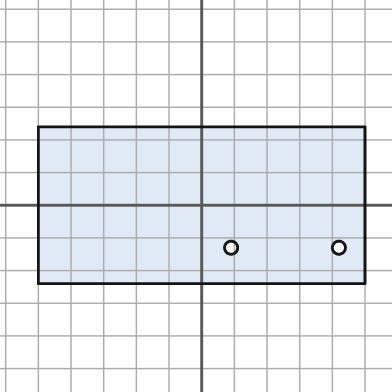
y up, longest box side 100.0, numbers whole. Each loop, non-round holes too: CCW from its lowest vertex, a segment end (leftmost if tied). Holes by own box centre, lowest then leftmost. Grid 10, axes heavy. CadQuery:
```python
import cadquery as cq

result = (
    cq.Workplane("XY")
    .moveTo(-50.0, -24.0)
    .lineTo(50.0, -24.0)
    .lineTo(50.0, 24.0)
    .lineTo(-50.0, 24.0)
    .close()
    .moveTo(9.0, -13.0)
    .circle(2.0)
    .moveTo(42.0, -13.0)
    .circle(2.0)
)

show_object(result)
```